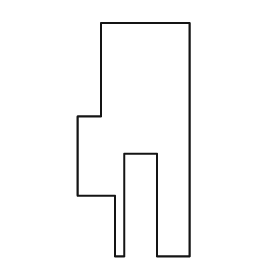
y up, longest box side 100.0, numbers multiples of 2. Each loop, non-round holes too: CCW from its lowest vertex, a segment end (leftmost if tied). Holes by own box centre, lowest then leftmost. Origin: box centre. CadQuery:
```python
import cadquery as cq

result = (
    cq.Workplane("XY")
    .moveTo(-8.0, -50.0)
    .lineTo(-4.0, -50.0)
    .lineTo(-4.0, -6.0)
    .lineTo(10.0, -6.0)
    .lineTo(10.0, -50.0)
    .lineTo(24.0, -50.0)
    .lineTo(24.0, 50.0)
    .lineTo(-14.0, 50.0)
    .lineTo(-14.0, 10.0)
    .lineTo(-24.0, 10.0)
    .lineTo(-24.0, -24.0)
    .lineTo(-8.0, -24.0)
    .close()
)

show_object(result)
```